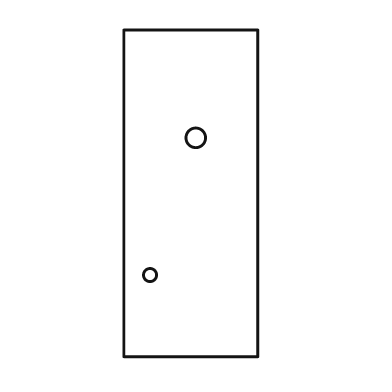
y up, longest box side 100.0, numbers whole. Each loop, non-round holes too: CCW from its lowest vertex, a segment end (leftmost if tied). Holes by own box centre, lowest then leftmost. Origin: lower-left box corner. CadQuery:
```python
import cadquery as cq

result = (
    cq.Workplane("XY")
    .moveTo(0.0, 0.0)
    .lineTo(41.0, 0.0)
    .lineTo(41.0, 100.0)
    .lineTo(0.0, 100.0)
    .close()
    .moveTo(8.0, 25.0)
    .circle(2.0)
    .moveTo(22.0, 67.0)
    .circle(3.0)
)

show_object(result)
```